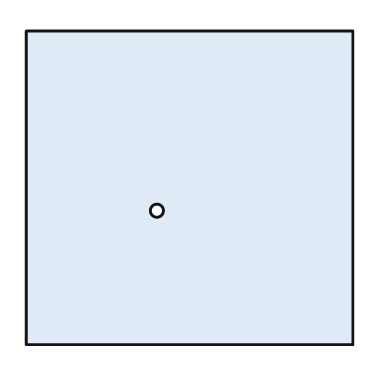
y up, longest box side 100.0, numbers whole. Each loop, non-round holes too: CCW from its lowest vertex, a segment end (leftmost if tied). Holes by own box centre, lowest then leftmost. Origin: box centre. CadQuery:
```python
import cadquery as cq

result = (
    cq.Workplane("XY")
    .moveTo(-50.0, -48.0)
    .lineTo(50.0, -48.0)
    .lineTo(50.0, 48.0)
    .lineTo(-50.0, 48.0)
    .close()
    .moveTo(-10.0, -7.0)
    .circle(2.0)
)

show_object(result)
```